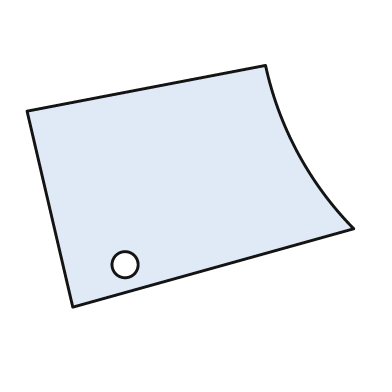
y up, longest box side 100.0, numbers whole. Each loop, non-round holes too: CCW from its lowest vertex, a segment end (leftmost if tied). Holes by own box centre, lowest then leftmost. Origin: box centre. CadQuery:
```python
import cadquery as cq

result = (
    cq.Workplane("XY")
    .moveTo(-36.0, -37.0)
    .lineTo(50.0, -13.0)
    .threePointArc((33.0, 10.0), (23.0, 37.0))
    .lineTo(-50.0, 23.0)
    .close()
    .moveTo(-20.0, -24.0)
    .circle(4.0)
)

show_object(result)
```